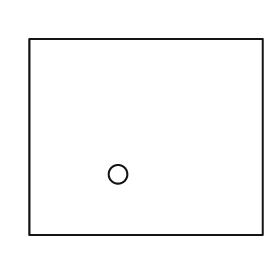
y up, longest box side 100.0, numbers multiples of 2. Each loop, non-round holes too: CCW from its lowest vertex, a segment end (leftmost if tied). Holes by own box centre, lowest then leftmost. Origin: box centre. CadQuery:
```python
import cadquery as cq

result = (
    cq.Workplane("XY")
    .moveTo(-50.0, -42.0)
    .lineTo(50.0, -42.0)
    .lineTo(50.0, 42.0)
    .lineTo(-50.0, 42.0)
    .close()
    .moveTo(-12.0, -16.0)
    .circle(4.0)
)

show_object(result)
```